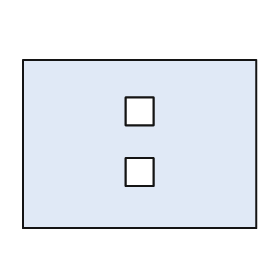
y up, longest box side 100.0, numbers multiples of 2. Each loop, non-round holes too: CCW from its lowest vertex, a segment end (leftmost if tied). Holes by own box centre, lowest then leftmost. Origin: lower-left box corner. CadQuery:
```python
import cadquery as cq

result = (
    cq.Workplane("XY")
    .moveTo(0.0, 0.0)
    .lineTo(100.0, 0.0)
    .lineTo(100.0, 72.0)
    .lineTo(0.0, 72.0)
    .close()
    .moveTo(44.0, 18.0)
    .lineTo(56.0, 18.0)
    .lineTo(56.0, 30.0)
    .lineTo(44.0, 30.0)
    .close()
    .moveTo(44.0, 44.0)
    .lineTo(56.0, 44.0)
    .lineTo(56.0, 56.0)
    .lineTo(44.0, 56.0)
    .close()
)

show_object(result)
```